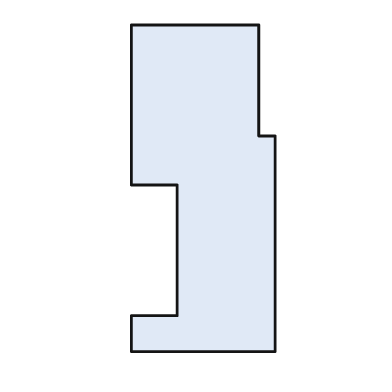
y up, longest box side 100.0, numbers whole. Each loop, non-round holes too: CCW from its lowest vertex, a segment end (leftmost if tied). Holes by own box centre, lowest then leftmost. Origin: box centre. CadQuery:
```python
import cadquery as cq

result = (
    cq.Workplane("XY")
    .moveTo(-22.0, -50.0)
    .lineTo(22.0, -50.0)
    .lineTo(22.0, 16.0)
    .lineTo(17.0, 16.0)
    .lineTo(17.0, 50.0)
    .lineTo(-22.0, 50.0)
    .lineTo(-22.0, 1.0)
    .lineTo(-8.0, 1.0)
    .lineTo(-8.0, -39.0)
    .lineTo(-22.0, -39.0)
    .close()
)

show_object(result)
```